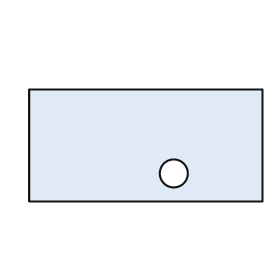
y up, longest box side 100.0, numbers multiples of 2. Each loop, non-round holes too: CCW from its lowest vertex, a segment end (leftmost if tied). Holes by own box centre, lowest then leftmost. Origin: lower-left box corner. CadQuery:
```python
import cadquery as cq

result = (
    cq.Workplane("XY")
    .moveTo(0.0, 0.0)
    .lineTo(100.0, 0.0)
    .lineTo(100.0, 48.0)
    .lineTo(0.0, 48.0)
    .close()
    .moveTo(62.0, 12.0)
    .circle(6.0)
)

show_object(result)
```